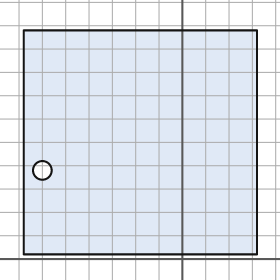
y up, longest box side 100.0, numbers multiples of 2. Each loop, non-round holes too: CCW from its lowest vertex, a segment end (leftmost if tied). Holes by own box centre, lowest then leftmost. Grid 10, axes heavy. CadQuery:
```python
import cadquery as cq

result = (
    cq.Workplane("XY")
    .moveTo(-68.0, 2.0)
    .lineTo(32.0, 2.0)
    .lineTo(32.0, 98.0)
    .lineTo(-68.0, 98.0)
    .close()
    .moveTo(-60.0, 38.0)
    .circle(4.0)
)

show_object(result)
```